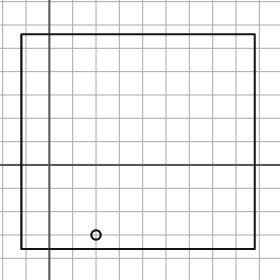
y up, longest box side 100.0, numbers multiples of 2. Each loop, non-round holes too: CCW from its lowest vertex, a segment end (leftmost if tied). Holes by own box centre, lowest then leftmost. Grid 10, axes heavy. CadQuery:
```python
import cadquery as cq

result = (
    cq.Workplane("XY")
    .moveTo(-12.0, -36.0)
    .lineTo(88.0, -36.0)
    .lineTo(88.0, 56.0)
    .lineTo(-12.0, 56.0)
    .close()
    .moveTo(20.0, -30.0)
    .circle(2.0)
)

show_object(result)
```